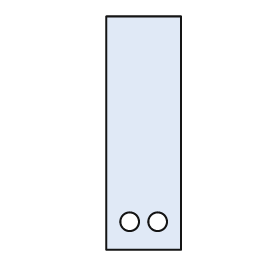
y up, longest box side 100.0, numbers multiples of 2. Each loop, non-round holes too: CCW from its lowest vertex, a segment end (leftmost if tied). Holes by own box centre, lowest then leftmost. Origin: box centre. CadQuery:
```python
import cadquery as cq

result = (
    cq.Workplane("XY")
    .moveTo(-16.0, -50.0)
    .lineTo(16.0, -50.0)
    .lineTo(16.0, 50.0)
    .lineTo(-16.0, 50.0)
    .close()
    .moveTo(-6.0, -38.0)
    .circle(4.0)
    .moveTo(6.0, -38.0)
    .circle(4.0)
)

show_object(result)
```